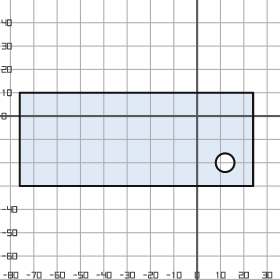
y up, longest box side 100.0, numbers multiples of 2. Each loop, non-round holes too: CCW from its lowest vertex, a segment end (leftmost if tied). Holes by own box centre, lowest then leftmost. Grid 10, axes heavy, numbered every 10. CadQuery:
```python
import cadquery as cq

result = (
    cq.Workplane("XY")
    .moveTo(-76.0, -30.0)
    .lineTo(24.0, -30.0)
    .lineTo(24.0, 10.0)
    .lineTo(-76.0, 10.0)
    .close()
    .moveTo(12.0, -20.0)
    .circle(4.0)
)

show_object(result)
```